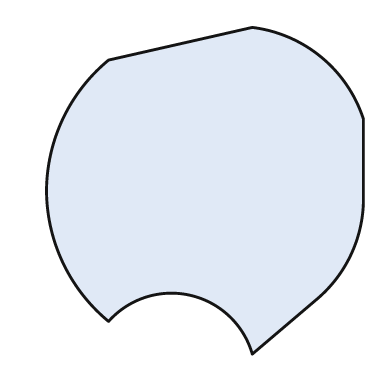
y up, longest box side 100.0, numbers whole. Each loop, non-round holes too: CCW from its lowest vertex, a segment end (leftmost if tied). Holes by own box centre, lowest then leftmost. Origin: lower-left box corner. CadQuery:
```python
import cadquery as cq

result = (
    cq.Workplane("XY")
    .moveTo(63.0, 0.0)
    .lineTo(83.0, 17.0)
    .threePointArc((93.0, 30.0), (97.0, 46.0))
    .lineTo(97.0, 72.0)
    .threePointArc((84.0, 91.0), (63.0, 100.0))
    .lineTo(19.0, 90.0)
    .threePointArc((5.0, 72.0), (0.0, 50.0))
    .threePointArc((5.0, 28.0), (19.0, 10.0))
    .threePointArc((44.0, 18.0), (63.0, 0.0))
    .close()
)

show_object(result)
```